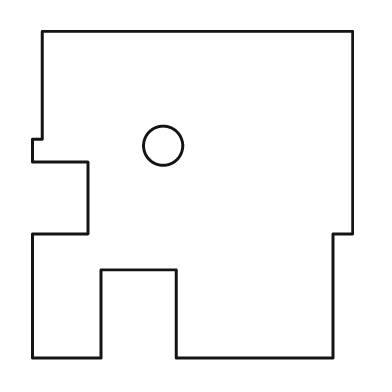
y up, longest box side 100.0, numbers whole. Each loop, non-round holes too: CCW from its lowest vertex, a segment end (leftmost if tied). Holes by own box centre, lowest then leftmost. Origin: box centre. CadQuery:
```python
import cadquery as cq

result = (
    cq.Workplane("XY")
    .moveTo(-49.0, -50.0)
    .lineTo(-28.0, -50.0)
    .lineTo(-28.0, -23.0)
    .lineTo(-5.0, -23.0)
    .lineTo(-5.0, -50.0)
    .lineTo(43.0, -50.0)
    .lineTo(43.0, -12.0)
    .lineTo(49.0, -12.0)
    .lineTo(49.0, 50.0)
    .lineTo(-46.0, 50.0)
    .lineTo(-46.0, 17.0)
    .lineTo(-49.0, 17.0)
    .lineTo(-49.0, 10.0)
    .lineTo(-32.0, 10.0)
    .lineTo(-32.0, -12.0)
    .lineTo(-49.0, -12.0)
    .close()
    .moveTo(-9.0, 15.0)
    .circle(6.0)
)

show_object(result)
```